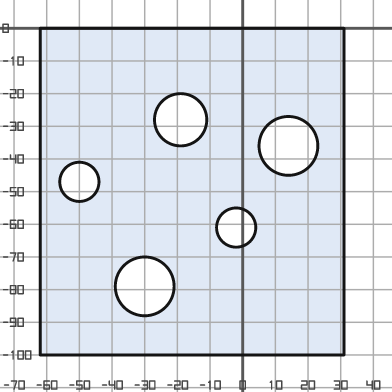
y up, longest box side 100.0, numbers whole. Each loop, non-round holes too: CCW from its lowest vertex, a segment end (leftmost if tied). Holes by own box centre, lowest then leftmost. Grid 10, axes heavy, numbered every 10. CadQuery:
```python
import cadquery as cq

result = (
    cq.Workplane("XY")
    .moveTo(-62.0, -100.0)
    .lineTo(31.0, -100.0)
    .lineTo(31.0, 0.0)
    .lineTo(-62.0, 0.0)
    .close()
    .moveTo(-30.0, -79.0)
    .circle(9.0)
    .moveTo(-2.0, -61.0)
    .circle(6.0)
    .moveTo(-50.0, -47.0)
    .circle(6.0)
    .moveTo(14.0, -36.0)
    .circle(9.0)
    .moveTo(-19.0, -28.0)
    .circle(8.0)
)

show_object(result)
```